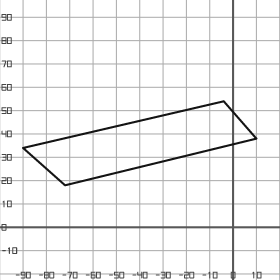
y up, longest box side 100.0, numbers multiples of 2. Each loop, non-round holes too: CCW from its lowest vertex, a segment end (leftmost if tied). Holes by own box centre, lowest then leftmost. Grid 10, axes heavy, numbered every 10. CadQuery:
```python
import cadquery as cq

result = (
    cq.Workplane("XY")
    .moveTo(-72.0, 18.0)
    .lineTo(10.0, 38.0)
    .lineTo(-4.0, 54.0)
    .lineTo(-90.0, 34.0)
    .close()
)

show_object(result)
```